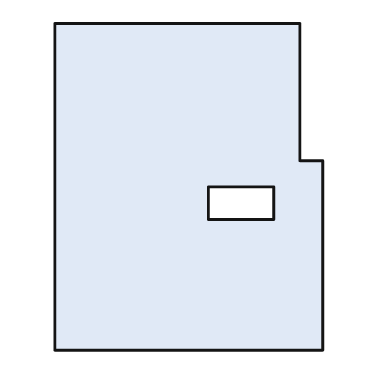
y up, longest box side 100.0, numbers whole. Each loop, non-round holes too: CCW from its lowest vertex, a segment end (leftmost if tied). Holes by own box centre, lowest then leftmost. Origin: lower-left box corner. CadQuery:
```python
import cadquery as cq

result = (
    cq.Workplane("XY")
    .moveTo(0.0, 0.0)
    .lineTo(82.0, 0.0)
    .lineTo(82.0, 58.0)
    .lineTo(75.0, 58.0)
    .lineTo(75.0, 100.0)
    .lineTo(0.0, 100.0)
    .close()
    .moveTo(47.0, 40.0)
    .lineTo(67.0, 40.0)
    .lineTo(67.0, 50.0)
    .lineTo(47.0, 50.0)
    .close()
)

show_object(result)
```